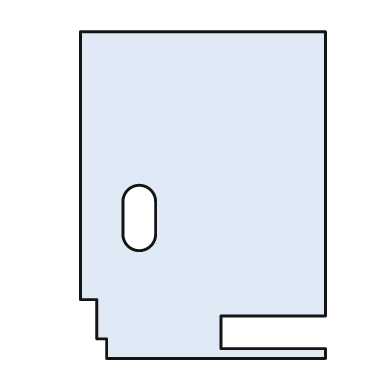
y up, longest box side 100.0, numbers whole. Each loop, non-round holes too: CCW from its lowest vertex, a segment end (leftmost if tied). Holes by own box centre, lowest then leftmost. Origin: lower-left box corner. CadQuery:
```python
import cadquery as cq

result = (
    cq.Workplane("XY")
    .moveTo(8.0, 0.0)
    .lineTo(75.0, 0.0)
    .lineTo(75.0, 3.0)
    .lineTo(43.0, 3.0)
    .lineTo(43.0, 13.0)
    .lineTo(75.0, 13.0)
    .lineTo(75.0, 100.0)
    .lineTo(0.0, 100.0)
    .lineTo(0.0, 18.0)
    .lineTo(5.0, 18.0)
    .lineTo(5.0, 6.0)
    .lineTo(8.0, 6.0)
    .close()
    .moveTo(13.0, 38.0)
    .threePointArc((18.0, 33.0), (23.0, 38.0))
    .lineTo(23.0, 48.0)
    .threePointArc((18.0, 53.0), (13.0, 48.0))
    .close()
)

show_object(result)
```